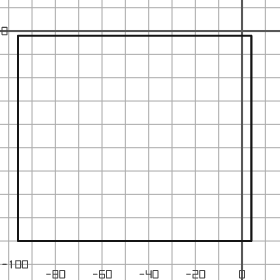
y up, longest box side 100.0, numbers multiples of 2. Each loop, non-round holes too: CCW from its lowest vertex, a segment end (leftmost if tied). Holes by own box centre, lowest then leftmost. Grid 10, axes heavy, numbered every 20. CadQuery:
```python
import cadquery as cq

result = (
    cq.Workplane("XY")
    .moveTo(-96.0, -90.0)
    .lineTo(4.0, -90.0)
    .lineTo(4.0, -2.0)
    .lineTo(-96.0, -2.0)
    .close()
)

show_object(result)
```